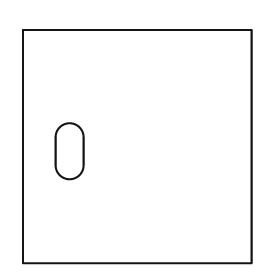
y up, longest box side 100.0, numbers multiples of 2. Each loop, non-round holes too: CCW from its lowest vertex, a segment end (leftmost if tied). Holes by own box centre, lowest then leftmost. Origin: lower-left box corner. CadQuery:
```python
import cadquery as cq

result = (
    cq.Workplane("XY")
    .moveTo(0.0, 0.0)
    .lineTo(98.0, 0.0)
    .lineTo(98.0, 100.0)
    .lineTo(0.0, 100.0)
    .close()
    .moveTo(14.0, 42.0)
    .threePointArc((20.0, 36.0), (26.0, 42.0))
    .lineTo(26.0, 54.0)
    .threePointArc((20.0, 60.0), (14.0, 54.0))
    .close()
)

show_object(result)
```